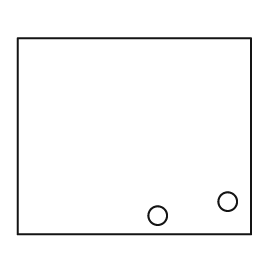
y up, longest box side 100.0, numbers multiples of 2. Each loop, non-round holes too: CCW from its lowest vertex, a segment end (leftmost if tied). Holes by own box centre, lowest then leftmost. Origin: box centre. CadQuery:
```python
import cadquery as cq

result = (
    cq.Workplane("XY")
    .moveTo(-50.0, -42.0)
    .lineTo(50.0, -42.0)
    .lineTo(50.0, 42.0)
    .lineTo(-50.0, 42.0)
    .close()
    .moveTo(10.0, -34.0)
    .circle(4.0)
    .moveTo(40.0, -28.0)
    .circle(4.0)
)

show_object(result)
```